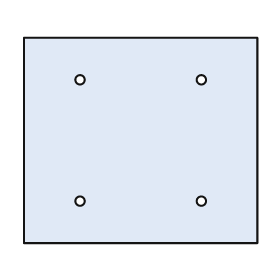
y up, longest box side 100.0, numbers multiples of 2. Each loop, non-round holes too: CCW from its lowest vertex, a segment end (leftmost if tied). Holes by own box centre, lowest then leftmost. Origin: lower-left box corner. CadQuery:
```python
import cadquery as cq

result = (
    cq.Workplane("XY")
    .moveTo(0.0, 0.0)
    .lineTo(100.0, 0.0)
    .lineTo(100.0, 88.0)
    .lineTo(0.0, 88.0)
    .close()
    .moveTo(24.0, 18.0)
    .circle(2.0)
    .moveTo(76.0, 18.0)
    .circle(2.0)
    .moveTo(24.0, 70.0)
    .circle(2.0)
    .moveTo(76.0, 70.0)
    .circle(2.0)
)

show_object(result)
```